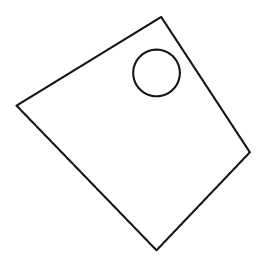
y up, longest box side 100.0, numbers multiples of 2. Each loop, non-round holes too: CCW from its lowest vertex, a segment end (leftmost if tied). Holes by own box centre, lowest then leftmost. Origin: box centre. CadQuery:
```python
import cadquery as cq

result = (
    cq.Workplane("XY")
    .moveTo(10.0, -50.0)
    .lineTo(50.0, -8.0)
    .lineTo(12.0, 50.0)
    .lineTo(-50.0, 12.0)
    .close()
    .moveTo(10.0, 26.0)
    .circle(10.0)
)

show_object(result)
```